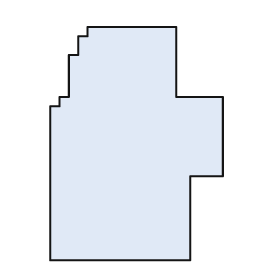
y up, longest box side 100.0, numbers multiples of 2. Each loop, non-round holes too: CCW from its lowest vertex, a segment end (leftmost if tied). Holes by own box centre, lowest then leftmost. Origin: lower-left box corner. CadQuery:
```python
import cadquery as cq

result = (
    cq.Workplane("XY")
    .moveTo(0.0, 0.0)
    .lineTo(60.0, 0.0)
    .lineTo(60.0, 36.0)
    .lineTo(74.0, 36.0)
    .lineTo(74.0, 70.0)
    .lineTo(54.0, 70.0)
    .lineTo(54.0, 100.0)
    .lineTo(16.0, 100.0)
    .lineTo(16.0, 96.0)
    .lineTo(12.0, 96.0)
    .lineTo(12.0, 88.0)
    .lineTo(8.0, 88.0)
    .lineTo(8.0, 70.0)
    .lineTo(4.0, 70.0)
    .lineTo(4.0, 66.0)
    .lineTo(0.0, 66.0)
    .close()
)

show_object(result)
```